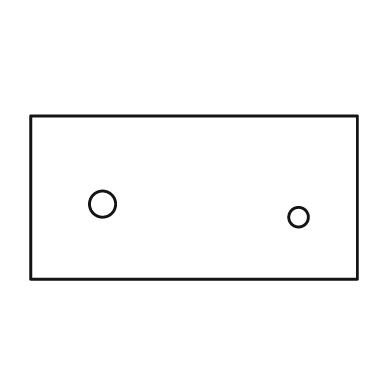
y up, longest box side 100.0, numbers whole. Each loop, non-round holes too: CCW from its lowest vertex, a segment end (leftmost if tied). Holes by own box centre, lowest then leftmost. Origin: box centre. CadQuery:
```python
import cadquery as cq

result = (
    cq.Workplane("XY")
    .moveTo(-50.0, -25.0)
    .lineTo(50.0, -25.0)
    .lineTo(50.0, 25.0)
    .lineTo(-50.0, 25.0)
    .close()
    .moveTo(32.0, -6.0)
    .circle(3.0)
    .moveTo(-28.0, -2.0)
    .circle(4.0)
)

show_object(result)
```